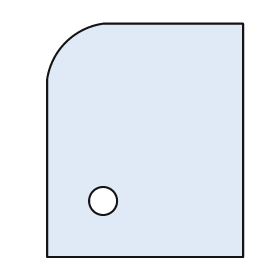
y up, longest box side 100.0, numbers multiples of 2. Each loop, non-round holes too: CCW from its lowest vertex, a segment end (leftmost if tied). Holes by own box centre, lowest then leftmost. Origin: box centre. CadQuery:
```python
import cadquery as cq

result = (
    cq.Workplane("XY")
    .moveTo(-42.0, -50.0)
    .lineTo(42.0, -50.0)
    .lineTo(42.0, 50.0)
    .lineTo(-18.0, 50.0)
    .threePointArc((-34.0, 42.0), (-42.0, 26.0))
    .close()
    .moveTo(-18.0, -26.0)
    .circle(6.0)
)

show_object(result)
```